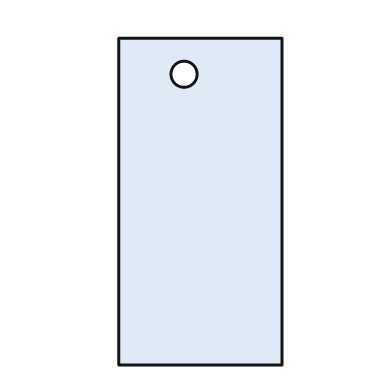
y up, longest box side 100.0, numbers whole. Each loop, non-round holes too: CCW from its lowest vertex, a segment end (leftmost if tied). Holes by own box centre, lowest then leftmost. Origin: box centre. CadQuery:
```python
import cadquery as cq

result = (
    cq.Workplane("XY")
    .moveTo(-25.0, -50.0)
    .lineTo(25.0, -50.0)
    .lineTo(25.0, 50.0)
    .lineTo(-25.0, 50.0)
    .close()
    .moveTo(-5.0, 39.0)
    .circle(4.0)
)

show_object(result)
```